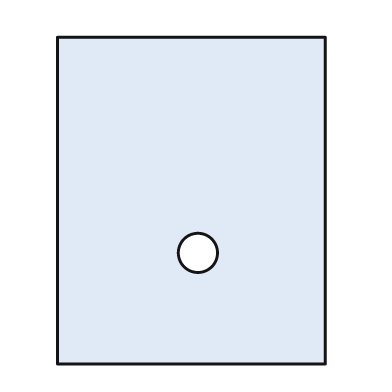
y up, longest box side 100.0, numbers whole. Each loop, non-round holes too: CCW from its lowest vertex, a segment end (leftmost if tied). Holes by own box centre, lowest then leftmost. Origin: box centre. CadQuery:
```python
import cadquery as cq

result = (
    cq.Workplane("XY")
    .moveTo(-41.0, -50.0)
    .lineTo(41.0, -50.0)
    .lineTo(41.0, 50.0)
    .lineTo(-41.0, 50.0)
    .close()
    .moveTo(2.0, -16.0)
    .circle(6.0)
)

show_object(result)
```